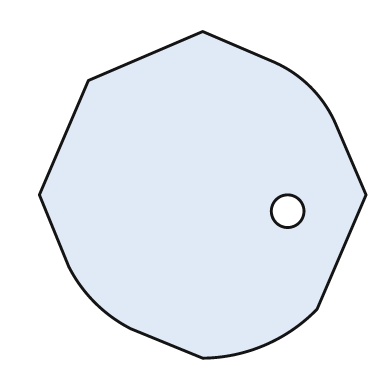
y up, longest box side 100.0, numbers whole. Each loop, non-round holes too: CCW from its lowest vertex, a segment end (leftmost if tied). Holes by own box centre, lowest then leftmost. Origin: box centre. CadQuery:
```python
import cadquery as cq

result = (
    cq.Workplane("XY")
    .moveTo(0.0, -50.0)
    .threePointArc((19.0, -46.0), (35.0, -35.0))
    .lineTo(50.0, 0.0)
    .lineTo(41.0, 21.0)
    .threePointArc((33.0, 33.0), (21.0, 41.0))
    .lineTo(0.0, 50.0)
    .lineTo(-35.0, 35.0)
    .lineTo(-50.0, 0.0)
    .lineTo(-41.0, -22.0)
    .threePointArc((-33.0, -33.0), (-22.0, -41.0))
    .close()
    .moveTo(26.0, -5.0)
    .circle(5.0)
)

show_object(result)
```